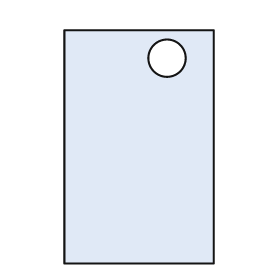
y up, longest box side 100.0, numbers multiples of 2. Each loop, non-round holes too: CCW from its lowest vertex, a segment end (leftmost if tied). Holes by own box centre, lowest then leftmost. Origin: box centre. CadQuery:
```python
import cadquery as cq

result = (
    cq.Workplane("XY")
    .moveTo(-32.0, -50.0)
    .lineTo(32.0, -50.0)
    .lineTo(32.0, 50.0)
    .lineTo(-32.0, 50.0)
    .close()
    .moveTo(12.0, 38.0)
    .circle(8.0)
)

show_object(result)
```